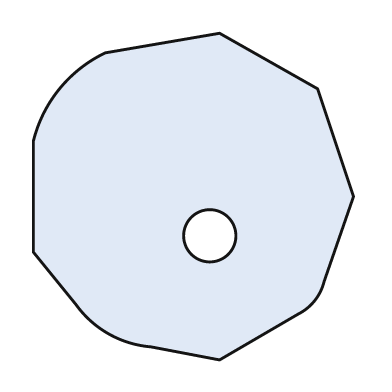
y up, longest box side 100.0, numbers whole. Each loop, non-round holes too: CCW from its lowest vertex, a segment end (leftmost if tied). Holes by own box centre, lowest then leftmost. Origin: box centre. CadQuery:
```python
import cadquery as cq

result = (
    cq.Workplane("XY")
    .moveTo(8.0, -50.0)
    .lineTo(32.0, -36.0)
    .threePointArc((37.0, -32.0), (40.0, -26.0))
    .lineTo(49.0, 0.0)
    .lineTo(38.0, 33.0)
    .lineTo(8.0, 50.0)
    .lineTo(-27.0, 44.0)
    .threePointArc((-41.0, 33.0), (-49.0, 17.0))
    .lineTo(-49.0, -17.0)
    .lineTo(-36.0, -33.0)
    .threePointArc((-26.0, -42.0), (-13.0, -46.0))
    .close()
    .moveTo(5.0, -12.0)
    .circle(8.0)
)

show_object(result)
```